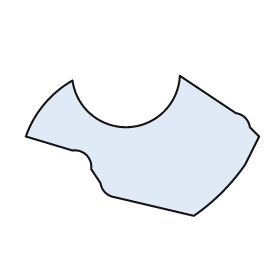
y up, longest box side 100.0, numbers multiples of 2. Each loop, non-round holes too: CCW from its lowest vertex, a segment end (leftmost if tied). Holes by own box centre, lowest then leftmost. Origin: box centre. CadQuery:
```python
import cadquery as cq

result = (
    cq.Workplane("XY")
    .moveTo(22.0, -30.0)
    .threePointArc((34.0, -20.0), (44.0, -8.0))
    .lineTo(50.0, 4.0)
    .lineTo(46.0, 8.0)
    .threePointArc((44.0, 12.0), (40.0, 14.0))
    .lineTo(16.0, 30.0)
    .threePointArc((-6.0, 8.0), (-30.0, 28.0))
    .threePointArc((-42.0, 18.0), (-50.0, 4.0))
    .lineTo(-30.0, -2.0)
    .threePointArc((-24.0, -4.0), (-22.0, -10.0))
    .lineTo(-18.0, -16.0)
    .threePointArc((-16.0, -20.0), (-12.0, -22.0))
    .close()
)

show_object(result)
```